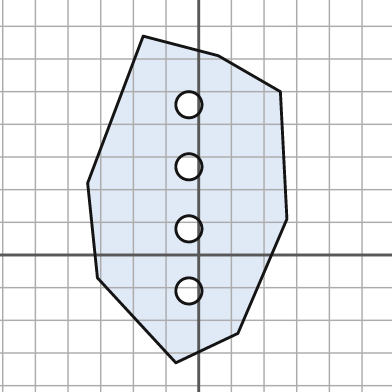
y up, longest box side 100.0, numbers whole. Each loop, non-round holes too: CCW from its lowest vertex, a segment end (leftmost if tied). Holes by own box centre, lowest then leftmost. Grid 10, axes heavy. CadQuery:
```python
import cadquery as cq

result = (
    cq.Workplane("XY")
    .moveTo(-7.0, -33.0)
    .lineTo(12.0, -24.0)
    .lineTo(27.0, 11.0)
    .lineTo(25.0, 50.0)
    .lineTo(6.0, 61.0)
    .lineTo(-17.0, 67.0)
    .lineTo(-34.0, 22.0)
    .lineTo(-31.0, -7.0)
    .close()
    .moveTo(-3.0, -11.0)
    .circle(4.0)
    .moveTo(-3.0, 8.0)
    .circle(4.0)
    .moveTo(-3.0, 27.0)
    .circle(4.0)
    .moveTo(-3.0, 46.0)
    .circle(4.0)
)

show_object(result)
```